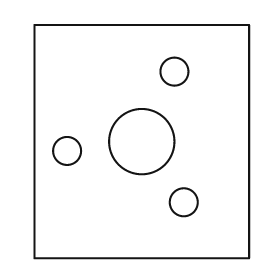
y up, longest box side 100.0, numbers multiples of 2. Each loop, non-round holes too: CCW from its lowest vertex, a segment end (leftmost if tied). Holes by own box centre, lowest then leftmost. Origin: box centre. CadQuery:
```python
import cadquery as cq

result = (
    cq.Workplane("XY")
    .moveTo(-46.0, -50.0)
    .lineTo(46.0, -50.0)
    .lineTo(46.0, 50.0)
    .lineTo(-46.0, 50.0)
    .close()
    .moveTo(18.0, -26.0)
    .circle(6.0)
    .moveTo(-32.0, -4.0)
    .circle(6.0)
    .moveTo(0.0, 0.0)
    .circle(14.0)
    .moveTo(14.0, 30.0)
    .circle(6.0)
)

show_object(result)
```